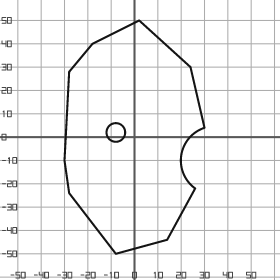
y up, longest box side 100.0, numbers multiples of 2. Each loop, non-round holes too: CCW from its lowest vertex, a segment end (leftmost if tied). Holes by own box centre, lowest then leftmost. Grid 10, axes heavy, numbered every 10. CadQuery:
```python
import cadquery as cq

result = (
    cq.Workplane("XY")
    .moveTo(-8.0, -50.0)
    .lineTo(14.0, -44.0)
    .lineTo(26.0, -22.0)
    .threePointArc((20.0, -8.0), (30.0, 4.0))
    .lineTo(24.0, 30.0)
    .lineTo(2.0, 50.0)
    .lineTo(-18.0, 40.0)
    .lineTo(-28.0, 28.0)
    .lineTo(-30.0, -10.0)
    .lineTo(-28.0, -24.0)
    .close()
    .moveTo(-8.0, 2.0)
    .circle(4.0)
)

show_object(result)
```